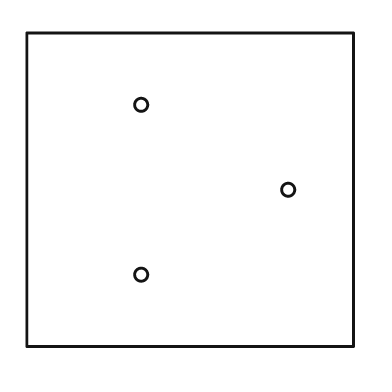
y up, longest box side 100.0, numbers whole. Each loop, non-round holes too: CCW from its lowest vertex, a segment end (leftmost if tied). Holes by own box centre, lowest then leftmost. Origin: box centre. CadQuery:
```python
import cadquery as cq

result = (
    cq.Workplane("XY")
    .moveTo(-50.0, -48.0)
    .lineTo(50.0, -48.0)
    .lineTo(50.0, 48.0)
    .lineTo(-50.0, 48.0)
    .close()
    .moveTo(-15.0, -26.0)
    .circle(2.0)
    .moveTo(30.0, 0.0)
    .circle(2.0)
    .moveTo(-15.0, 26.0)
    .circle(2.0)
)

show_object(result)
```